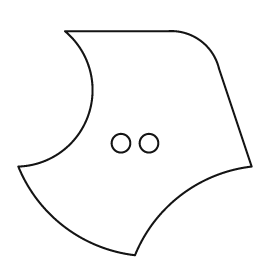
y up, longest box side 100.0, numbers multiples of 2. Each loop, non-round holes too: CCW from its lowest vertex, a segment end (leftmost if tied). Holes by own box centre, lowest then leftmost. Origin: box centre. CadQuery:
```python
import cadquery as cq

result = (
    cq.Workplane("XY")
    .moveTo(0.0, -48.0)
    .threePointArc((20.0, -22.0), (50.0, -10.0))
    .lineTo(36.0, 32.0)
    .threePointArc((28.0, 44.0), (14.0, 48.0))
    .lineTo(-30.0, 48.0)
    .threePointArc((-20.0, 12.0), (-50.0, -10.0))
    .threePointArc((-30.0, -36.0), (0.0, -48.0))
    .close()
    .moveTo(-6.0, 0.0)
    .circle(4.0)
    .moveTo(6.0, 0.0)
    .circle(4.0)
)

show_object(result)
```